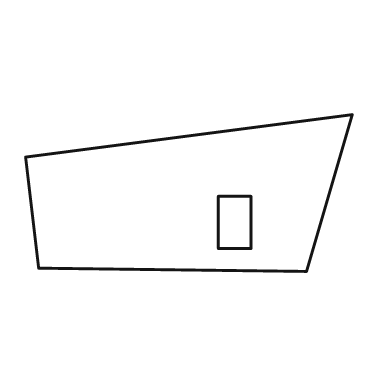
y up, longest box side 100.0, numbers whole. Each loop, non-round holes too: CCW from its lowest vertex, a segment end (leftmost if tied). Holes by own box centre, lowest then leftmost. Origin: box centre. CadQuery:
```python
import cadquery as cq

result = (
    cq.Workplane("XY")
    .moveTo(36.0, -24.0)
    .lineTo(50.0, 24.0)
    .lineTo(-50.0, 11.0)
    .lineTo(-46.0, -23.0)
    .close()
    .moveTo(9.0, -17.0)
    .lineTo(19.0, -17.0)
    .lineTo(19.0, -1.0)
    .lineTo(9.0, -1.0)
    .close()
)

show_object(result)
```